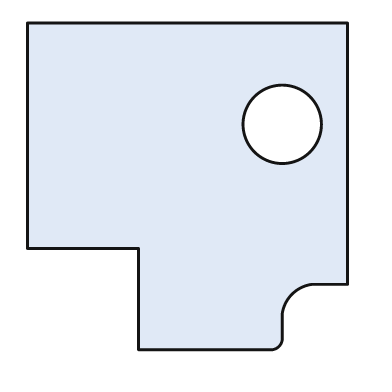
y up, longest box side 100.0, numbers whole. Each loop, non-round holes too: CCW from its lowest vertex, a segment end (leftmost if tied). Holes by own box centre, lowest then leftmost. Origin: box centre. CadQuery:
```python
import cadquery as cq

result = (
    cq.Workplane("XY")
    .moveTo(-15.0, -50.0)
    .lineTo(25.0, -50.0)
    .threePointArc((28.0, -49.0), (29.0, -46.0))
    .lineTo(29.0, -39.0)
    .threePointArc((32.0, -33.0), (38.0, -30.0))
    .lineTo(49.0, -30.0)
    .lineTo(49.0, 50.0)
    .lineTo(-49.0, 50.0)
    .lineTo(-49.0, -19.0)
    .lineTo(-15.0, -19.0)
    .close()
    .moveTo(29.0, 19.0)
    .circle(12.0)
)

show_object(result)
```